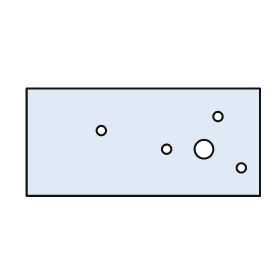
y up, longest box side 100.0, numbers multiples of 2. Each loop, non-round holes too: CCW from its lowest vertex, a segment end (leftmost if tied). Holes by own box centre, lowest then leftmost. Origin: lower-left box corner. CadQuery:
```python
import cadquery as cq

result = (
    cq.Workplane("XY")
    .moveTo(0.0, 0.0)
    .lineTo(100.0, 0.0)
    .lineTo(100.0, 46.0)
    .lineTo(0.0, 46.0)
    .close()
    .moveTo(92.0, 12.0)
    .circle(2.0)
    .moveTo(60.0, 20.0)
    .circle(2.0)
    .moveTo(76.0, 20.0)
    .circle(4.0)
    .moveTo(32.0, 28.0)
    .circle(2.0)
    .moveTo(82.0, 34.0)
    .circle(2.0)
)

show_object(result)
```